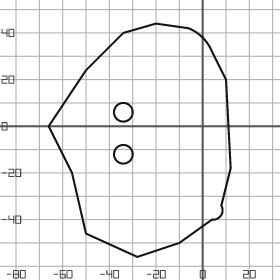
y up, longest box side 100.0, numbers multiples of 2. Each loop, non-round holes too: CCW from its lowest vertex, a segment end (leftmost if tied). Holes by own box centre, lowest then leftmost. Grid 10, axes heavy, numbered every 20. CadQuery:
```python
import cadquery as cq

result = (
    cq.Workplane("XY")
    .moveTo(-28.0, -56.0)
    .lineTo(-10.0, -50.0)
    .lineTo(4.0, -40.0)
    .threePointArc((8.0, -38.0), (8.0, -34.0))
    .lineTo(12.0, -18.0)
    .lineTo(10.0, 20.0)
    .lineTo(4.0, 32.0)
    .threePointArc((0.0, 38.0), (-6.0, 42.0))
    .lineTo(-20.0, 44.0)
    .lineTo(-34.0, 40.0)
    .lineTo(-50.0, 24.0)
    .lineTo(-66.0, 0.0)
    .lineTo(-56.0, -20.0)
    .lineTo(-50.0, -46.0)
    .close()
    .moveTo(-34.0, -12.0)
    .circle(4.0)
    .moveTo(-34.0, 6.0)
    .circle(4.0)
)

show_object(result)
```